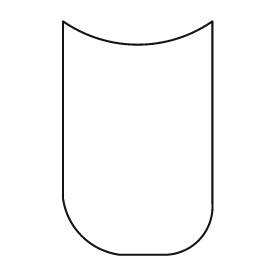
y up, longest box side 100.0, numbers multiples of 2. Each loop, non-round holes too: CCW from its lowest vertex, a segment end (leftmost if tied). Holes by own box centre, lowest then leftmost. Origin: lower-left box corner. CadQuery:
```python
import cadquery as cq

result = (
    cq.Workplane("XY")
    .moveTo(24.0, 0.0)
    .lineTo(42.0, 0.0)
    .threePointArc((58.0, 6.0), (64.0, 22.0))
    .lineTo(64.0, 100.0)
    .threePointArc((32.0, 90.0), (0.0, 100.0))
    .lineTo(0.0, 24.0)
    .threePointArc((8.0, 8.0), (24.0, 0.0))
    .close()
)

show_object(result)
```